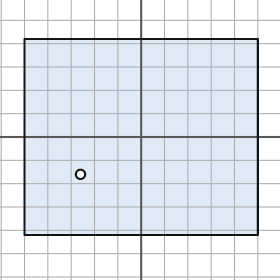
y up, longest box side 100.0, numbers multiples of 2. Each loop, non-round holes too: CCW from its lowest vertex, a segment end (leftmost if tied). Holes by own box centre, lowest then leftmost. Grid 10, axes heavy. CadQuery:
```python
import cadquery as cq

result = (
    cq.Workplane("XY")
    .moveTo(-50.0, -42.0)
    .lineTo(50.0, -42.0)
    .lineTo(50.0, 42.0)
    .lineTo(-50.0, 42.0)
    .close()
    .moveTo(-26.0, -16.0)
    .circle(2.0)
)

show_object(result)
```